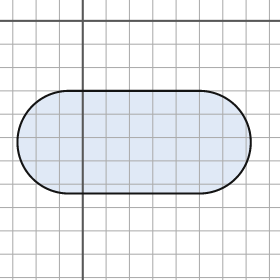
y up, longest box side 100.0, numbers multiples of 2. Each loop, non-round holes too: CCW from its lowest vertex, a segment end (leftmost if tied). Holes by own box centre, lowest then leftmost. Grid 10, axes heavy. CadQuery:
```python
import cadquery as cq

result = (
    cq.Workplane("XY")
    .moveTo(-6.0, -74.0)
    .lineTo(50.0, -74.0)
    .threePointArc((72.0, -52.0), (50.0, -30.0))
    .lineTo(-6.0, -30.0)
    .threePointArc((-28.0, -52.0), (-6.0, -74.0))
    .close()
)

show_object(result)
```